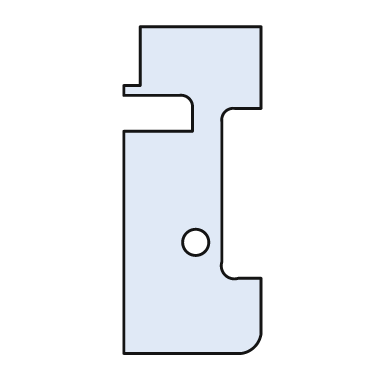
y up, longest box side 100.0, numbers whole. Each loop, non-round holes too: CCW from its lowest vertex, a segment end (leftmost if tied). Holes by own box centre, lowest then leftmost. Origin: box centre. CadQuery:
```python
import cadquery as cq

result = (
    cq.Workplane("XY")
    .moveTo(-21.0, -50.0)
    .lineTo(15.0, -50.0)
    .threePointArc((19.0, -48.0), (21.0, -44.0))
    .lineTo(21.0, -27.0)
    .lineTo(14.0, -27.0)
    .threePointArc((10.0, -26.0), (9.0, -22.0))
    .lineTo(9.0, 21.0)
    .threePointArc((10.0, 24.0), (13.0, 25.0))
    .lineTo(21.0, 25.0)
    .lineTo(21.0, 50.0)
    .lineTo(-16.0, 50.0)
    .lineTo(-16.0, 32.0)
    .lineTo(-21.0, 32.0)
    .lineTo(-21.0, 29.0)
    .lineTo(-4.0, 29.0)
    .threePointArc((-1.0, 28.0), (0.0, 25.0))
    .lineTo(0.0, 18.0)
    .lineTo(-21.0, 18.0)
    .close()
    .moveTo(1.0, -16.0)
    .circle(4.0)
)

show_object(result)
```